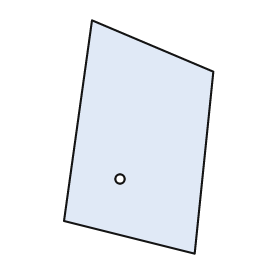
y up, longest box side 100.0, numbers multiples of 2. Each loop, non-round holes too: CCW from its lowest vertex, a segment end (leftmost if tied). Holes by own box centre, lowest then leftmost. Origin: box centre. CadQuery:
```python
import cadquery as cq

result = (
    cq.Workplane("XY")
    .moveTo(24.0, -50.0)
    .lineTo(32.0, 28.0)
    .lineTo(-20.0, 50.0)
    .lineTo(-32.0, -36.0)
    .close()
    .moveTo(-8.0, -18.0)
    .circle(2.0)
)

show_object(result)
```